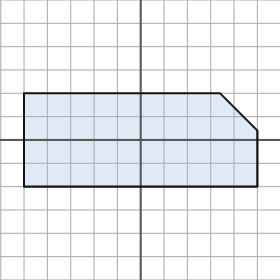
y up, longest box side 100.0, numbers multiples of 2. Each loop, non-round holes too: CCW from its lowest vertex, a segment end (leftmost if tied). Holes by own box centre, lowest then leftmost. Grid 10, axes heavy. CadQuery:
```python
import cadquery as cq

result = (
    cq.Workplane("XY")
    .moveTo(-50.0, -20.0)
    .lineTo(50.0, -20.0)
    .lineTo(50.0, 4.0)
    .lineTo(34.0, 20.0)
    .lineTo(-50.0, 20.0)
    .close()
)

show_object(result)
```